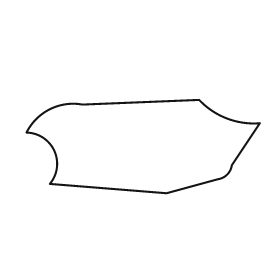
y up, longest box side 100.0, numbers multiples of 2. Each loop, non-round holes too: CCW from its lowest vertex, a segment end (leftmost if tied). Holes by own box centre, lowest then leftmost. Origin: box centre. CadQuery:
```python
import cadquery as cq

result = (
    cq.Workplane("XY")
    .moveTo(10.0, -20.0)
    .lineTo(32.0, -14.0)
    .threePointArc((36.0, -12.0), (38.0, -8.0))
    .lineTo(50.0, 10.0)
    .threePointArc((36.0, 12.0), (24.0, 20.0))
    .lineTo(-26.0, 18.0)
    .threePointArc((-40.0, 16.0), (-50.0, 6.0))
    .threePointArc((-38.0, -2.0), (-40.0, -16.0))
    .close()
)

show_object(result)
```